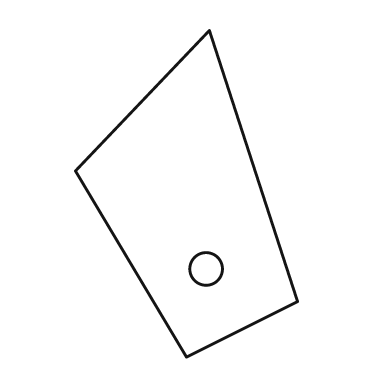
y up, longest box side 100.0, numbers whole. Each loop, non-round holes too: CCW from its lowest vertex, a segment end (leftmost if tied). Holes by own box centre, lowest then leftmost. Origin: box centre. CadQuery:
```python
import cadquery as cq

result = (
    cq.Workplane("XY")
    .moveTo(0.0, -50.0)
    .lineTo(34.0, -33.0)
    .lineTo(7.0, 50.0)
    .lineTo(-34.0, 7.0)
    .close()
    .moveTo(6.0, -23.0)
    .circle(5.0)
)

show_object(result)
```